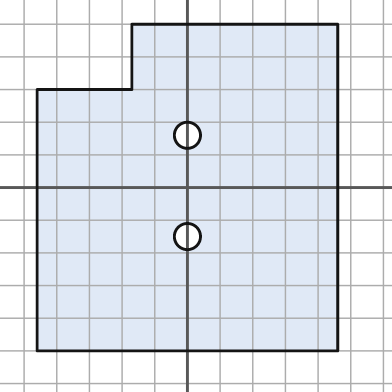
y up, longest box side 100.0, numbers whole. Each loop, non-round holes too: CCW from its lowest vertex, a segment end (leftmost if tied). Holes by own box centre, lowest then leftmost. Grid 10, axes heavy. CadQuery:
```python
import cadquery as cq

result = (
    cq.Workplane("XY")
    .moveTo(-46.0, -50.0)
    .lineTo(46.0, -50.0)
    .lineTo(46.0, 50.0)
    .lineTo(-17.0, 50.0)
    .lineTo(-17.0, 30.0)
    .lineTo(-46.0, 30.0)
    .close()
    .moveTo(0.0, -15.0)
    .circle(4.0)
    .moveTo(0.0, 16.0)
    .circle(4.0)
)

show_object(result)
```